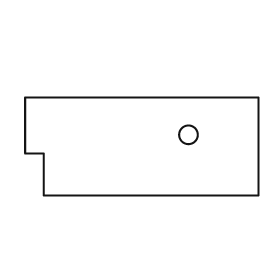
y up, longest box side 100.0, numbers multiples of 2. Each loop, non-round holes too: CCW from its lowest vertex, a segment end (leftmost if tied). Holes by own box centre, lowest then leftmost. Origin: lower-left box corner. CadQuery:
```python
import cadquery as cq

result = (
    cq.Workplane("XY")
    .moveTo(8.0, 0.0)
    .lineTo(100.0, 0.0)
    .lineTo(100.0, 42.0)
    .lineTo(0.0, 42.0)
    .lineTo(0.0, 18.0)
    .lineTo(8.0, 18.0)
    .close()
    .moveTo(70.0, 26.0)
    .circle(4.0)
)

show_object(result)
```